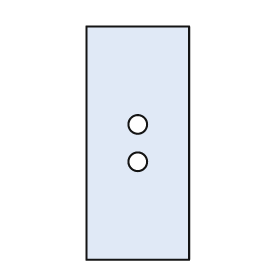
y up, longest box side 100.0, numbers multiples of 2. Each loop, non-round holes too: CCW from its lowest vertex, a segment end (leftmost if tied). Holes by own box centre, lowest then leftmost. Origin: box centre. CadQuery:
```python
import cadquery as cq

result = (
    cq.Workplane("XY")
    .moveTo(-22.0, -50.0)
    .lineTo(22.0, -50.0)
    .lineTo(22.0, 50.0)
    .lineTo(-22.0, 50.0)
    .close()
    .moveTo(0.0, -8.0)
    .circle(4.0)
    .moveTo(0.0, 8.0)
    .circle(4.0)
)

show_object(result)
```